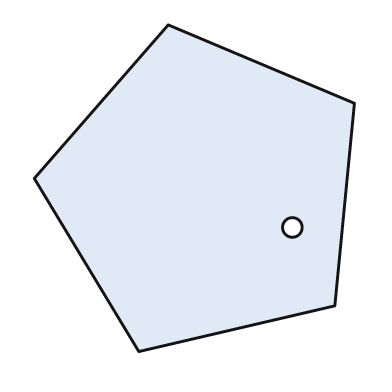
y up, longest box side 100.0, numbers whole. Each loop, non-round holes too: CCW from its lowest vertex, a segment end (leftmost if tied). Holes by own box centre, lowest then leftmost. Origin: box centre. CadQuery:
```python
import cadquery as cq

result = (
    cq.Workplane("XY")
    .moveTo(-17.0, -50.0)
    .lineTo(43.0, -36.0)
    .lineTo(49.0, 26.0)
    .lineTo(-8.0, 50.0)
    .lineTo(-49.0, 3.0)
    .close()
    .moveTo(30.0, -12.0)
    .circle(3.0)
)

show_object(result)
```